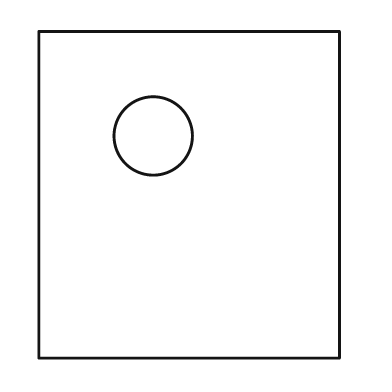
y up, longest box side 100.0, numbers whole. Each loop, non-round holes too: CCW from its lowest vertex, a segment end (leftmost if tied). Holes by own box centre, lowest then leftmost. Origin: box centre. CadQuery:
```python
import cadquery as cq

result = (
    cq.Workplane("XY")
    .moveTo(-46.0, -50.0)
    .lineTo(46.0, -50.0)
    .lineTo(46.0, 50.0)
    .lineTo(-46.0, 50.0)
    .close()
    .moveTo(-11.0, 18.0)
    .circle(12.0)
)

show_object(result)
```